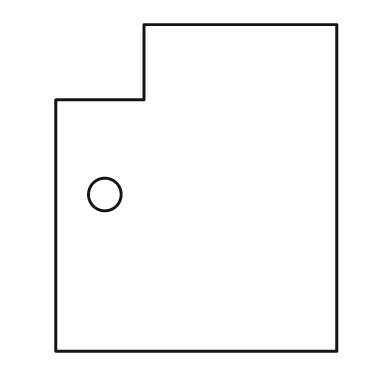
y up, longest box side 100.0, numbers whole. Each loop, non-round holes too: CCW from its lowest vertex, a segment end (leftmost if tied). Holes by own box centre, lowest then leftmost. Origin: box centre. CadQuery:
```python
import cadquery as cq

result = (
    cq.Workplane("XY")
    .moveTo(-43.0, -50.0)
    .lineTo(43.0, -50.0)
    .lineTo(43.0, 50.0)
    .lineTo(-16.0, 50.0)
    .lineTo(-16.0, 27.0)
    .lineTo(-43.0, 27.0)
    .close()
    .moveTo(-28.0, -2.0)
    .circle(5.0)
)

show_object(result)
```